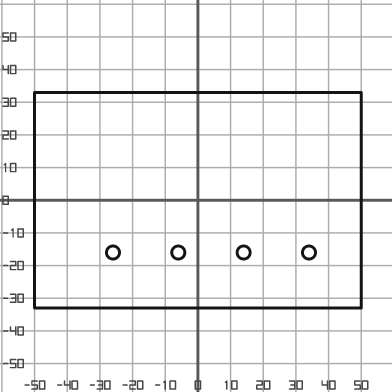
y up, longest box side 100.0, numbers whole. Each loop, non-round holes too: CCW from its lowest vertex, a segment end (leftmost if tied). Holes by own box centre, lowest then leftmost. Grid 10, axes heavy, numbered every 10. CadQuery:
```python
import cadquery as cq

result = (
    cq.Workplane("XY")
    .moveTo(-50.0, -33.0)
    .lineTo(50.0, -33.0)
    .lineTo(50.0, 33.0)
    .lineTo(-50.0, 33.0)
    .close()
    .moveTo(-26.0, -16.0)
    .circle(2.0)
    .moveTo(-6.0, -16.0)
    .circle(2.0)
    .moveTo(14.0, -16.0)
    .circle(2.0)
    .moveTo(34.0, -16.0)
    .circle(2.0)
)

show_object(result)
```